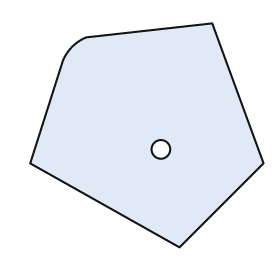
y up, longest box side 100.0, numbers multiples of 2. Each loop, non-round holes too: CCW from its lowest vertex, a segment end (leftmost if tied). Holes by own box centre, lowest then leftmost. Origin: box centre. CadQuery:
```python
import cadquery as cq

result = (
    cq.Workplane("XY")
    .moveTo(14.0, -48.0)
    .lineTo(50.0, -12.0)
    .lineTo(28.0, 48.0)
    .lineTo(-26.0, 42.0)
    .threePointArc((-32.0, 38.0), (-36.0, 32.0))
    .lineTo(-50.0, -12.0)
    .close()
    .moveTo(6.0, -6.0)
    .circle(4.0)
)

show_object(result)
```